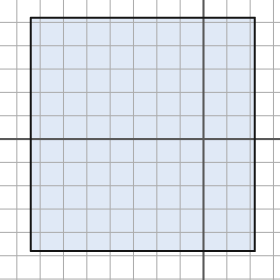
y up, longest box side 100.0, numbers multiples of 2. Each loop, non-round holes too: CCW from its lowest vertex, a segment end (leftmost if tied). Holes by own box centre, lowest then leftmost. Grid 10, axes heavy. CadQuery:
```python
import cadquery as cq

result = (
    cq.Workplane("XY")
    .moveTo(-74.0, -48.0)
    .lineTo(22.0, -48.0)
    .lineTo(22.0, 52.0)
    .lineTo(-74.0, 52.0)
    .close()
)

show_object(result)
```